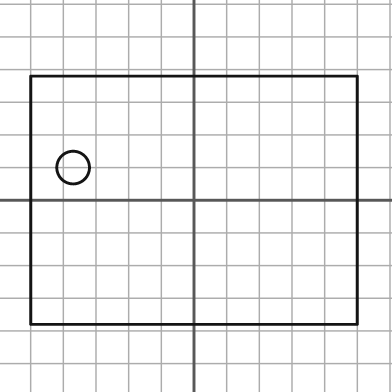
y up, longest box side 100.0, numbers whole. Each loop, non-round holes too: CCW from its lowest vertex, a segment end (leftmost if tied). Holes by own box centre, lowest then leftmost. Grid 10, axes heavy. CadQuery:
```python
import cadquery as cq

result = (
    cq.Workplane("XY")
    .moveTo(-50.0, -38.0)
    .lineTo(50.0, -38.0)
    .lineTo(50.0, 38.0)
    .lineTo(-50.0, 38.0)
    .close()
    .moveTo(-37.0, 10.0)
    .circle(5.0)
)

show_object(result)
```